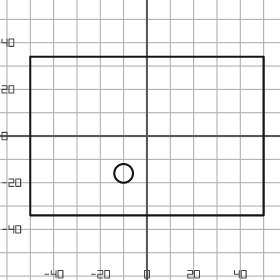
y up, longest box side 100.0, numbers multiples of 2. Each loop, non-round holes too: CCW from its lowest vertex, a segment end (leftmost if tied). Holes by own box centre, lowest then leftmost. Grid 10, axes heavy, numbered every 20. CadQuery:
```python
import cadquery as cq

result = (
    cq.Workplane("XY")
    .moveTo(-50.0, -34.0)
    .lineTo(50.0, -34.0)
    .lineTo(50.0, 34.0)
    .lineTo(-50.0, 34.0)
    .close()
    .moveTo(-10.0, -16.0)
    .circle(4.0)
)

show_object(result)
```